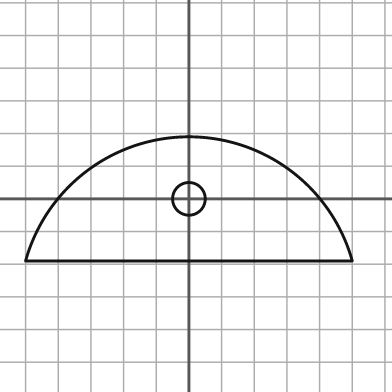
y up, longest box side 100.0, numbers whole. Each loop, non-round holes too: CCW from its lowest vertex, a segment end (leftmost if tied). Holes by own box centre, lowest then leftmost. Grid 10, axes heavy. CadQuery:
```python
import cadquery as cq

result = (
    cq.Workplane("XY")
    .moveTo(-50.0, -19.0)
    .lineTo(50.0, -19.0)
    .threePointArc((0.0, 19.0), (-50.0, -19.0))
    .close()
    .moveTo(0.0, 0.0)
    .circle(5.0)
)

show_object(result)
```